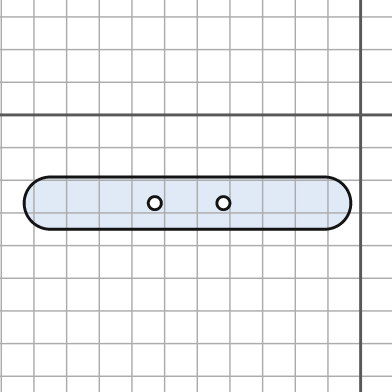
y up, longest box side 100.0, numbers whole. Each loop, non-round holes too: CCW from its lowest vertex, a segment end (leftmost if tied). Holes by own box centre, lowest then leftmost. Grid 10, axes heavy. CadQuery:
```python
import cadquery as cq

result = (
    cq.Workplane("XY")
    .moveTo(-95.0, -35.0)
    .lineTo(-11.0, -35.0)
    .threePointArc((-3.0, -27.0), (-11.0, -19.0))
    .lineTo(-95.0, -19.0)
    .threePointArc((-103.0, -27.0), (-95.0, -35.0))
    .close()
    .moveTo(-63.0, -27.0)
    .circle(2.0)
    .moveTo(-42.0, -27.0)
    .circle(2.0)
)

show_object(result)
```